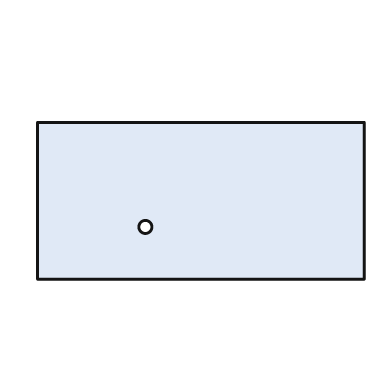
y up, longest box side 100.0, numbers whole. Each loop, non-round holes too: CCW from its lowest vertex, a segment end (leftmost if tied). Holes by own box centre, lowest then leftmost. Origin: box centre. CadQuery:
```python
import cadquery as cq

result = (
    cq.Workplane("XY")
    .moveTo(-50.0, -24.0)
    .lineTo(50.0, -24.0)
    .lineTo(50.0, 24.0)
    .lineTo(-50.0, 24.0)
    .close()
    .moveTo(-17.0, -8.0)
    .circle(2.0)
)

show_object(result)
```